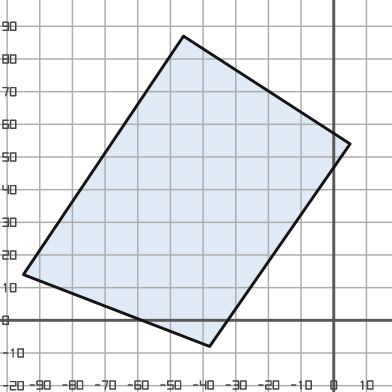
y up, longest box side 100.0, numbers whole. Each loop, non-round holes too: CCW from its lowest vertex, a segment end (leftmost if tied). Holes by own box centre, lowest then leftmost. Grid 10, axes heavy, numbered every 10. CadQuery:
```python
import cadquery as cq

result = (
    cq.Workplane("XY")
    .moveTo(-38.0, -8.0)
    .lineTo(5.0, 54.0)
    .lineTo(-46.0, 87.0)
    .lineTo(-95.0, 14.0)
    .close()
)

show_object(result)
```